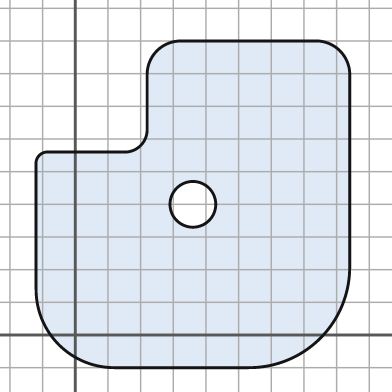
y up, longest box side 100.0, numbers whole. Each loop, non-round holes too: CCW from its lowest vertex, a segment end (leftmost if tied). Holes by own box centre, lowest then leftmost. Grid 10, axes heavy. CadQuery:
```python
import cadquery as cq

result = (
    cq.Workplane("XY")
    .moveTo(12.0, -10.0)
    .lineTo(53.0, -10.0)
    .threePointArc((75.0, -1.0), (84.0, 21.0))
    .lineTo(84.0, 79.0)
    .threePointArc((81.0, 87.0), (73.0, 90.0))
    .lineTo(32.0, 90.0)
    .threePointArc((25.0, 87.0), (22.0, 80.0))
    .lineTo(22.0, 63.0)
    .threePointArc((20.0, 58.0), (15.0, 56.0))
    .lineTo(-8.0, 56.0)
    .threePointArc((-11.0, 55.0), (-12.0, 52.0))
    .lineTo(-12.0, 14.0)
    .threePointArc((-5.0, -3.0), (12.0, -10.0))
    .close()
    .moveTo(36.0, 40.0)
    .circle(7.0)
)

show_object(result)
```